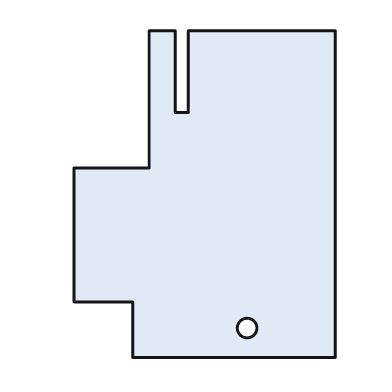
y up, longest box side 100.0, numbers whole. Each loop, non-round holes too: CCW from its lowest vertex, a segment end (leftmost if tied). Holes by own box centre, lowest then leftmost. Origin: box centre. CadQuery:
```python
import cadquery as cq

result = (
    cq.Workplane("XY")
    .moveTo(-22.0, -50.0)
    .lineTo(40.0, -50.0)
    .lineTo(40.0, 50.0)
    .lineTo(-5.0, 50.0)
    .lineTo(-5.0, 25.0)
    .lineTo(-9.0, 25.0)
    .lineTo(-9.0, 50.0)
    .lineTo(-17.0, 50.0)
    .lineTo(-17.0, 8.0)
    .lineTo(-40.0, 8.0)
    .lineTo(-40.0, -33.0)
    .lineTo(-22.0, -33.0)
    .close()
    .moveTo(13.0, -41.0)
    .circle(3.0)
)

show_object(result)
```